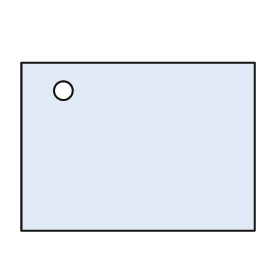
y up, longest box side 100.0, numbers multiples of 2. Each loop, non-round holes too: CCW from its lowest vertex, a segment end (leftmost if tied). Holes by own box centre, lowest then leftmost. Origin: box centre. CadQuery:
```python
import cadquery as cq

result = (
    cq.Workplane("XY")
    .moveTo(-50.0, -36.0)
    .lineTo(50.0, -36.0)
    .lineTo(50.0, 36.0)
    .lineTo(-50.0, 36.0)
    .close()
    .moveTo(-32.0, 24.0)
    .circle(4.0)
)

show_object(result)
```